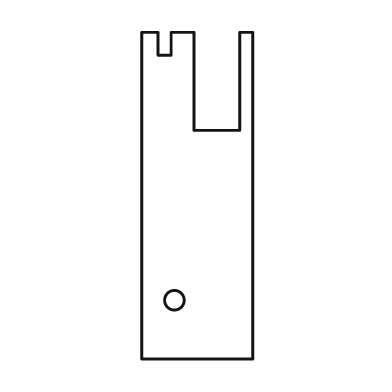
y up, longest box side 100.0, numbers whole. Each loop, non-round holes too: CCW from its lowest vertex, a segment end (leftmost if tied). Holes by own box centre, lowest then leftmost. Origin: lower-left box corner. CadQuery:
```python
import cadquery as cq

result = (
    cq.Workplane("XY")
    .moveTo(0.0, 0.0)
    .lineTo(34.0, 0.0)
    .lineTo(34.0, 100.0)
    .lineTo(30.0, 100.0)
    .lineTo(30.0, 70.0)
    .lineTo(16.0, 70.0)
    .lineTo(16.0, 100.0)
    .lineTo(9.0, 100.0)
    .lineTo(9.0, 93.0)
    .lineTo(5.0, 93.0)
    .lineTo(5.0, 100.0)
    .lineTo(0.0, 100.0)
    .close()
    .moveTo(10.0, 18.0)
    .circle(3.0)
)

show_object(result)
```